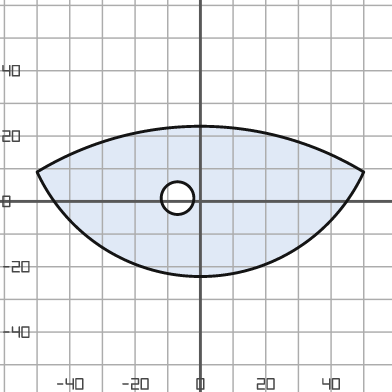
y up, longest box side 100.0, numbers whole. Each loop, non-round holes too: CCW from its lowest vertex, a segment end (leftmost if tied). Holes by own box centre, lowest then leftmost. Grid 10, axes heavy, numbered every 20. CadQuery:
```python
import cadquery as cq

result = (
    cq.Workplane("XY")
    .moveTo(-50.0, 9.0)
    .threePointArc((0.0, -23.0), (50.0, 9.0))
    .threePointArc((0.0, 23.0), (-50.0, 9.0))
    .close()
    .moveTo(-7.0, 1.0)
    .circle(5.0)
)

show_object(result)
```